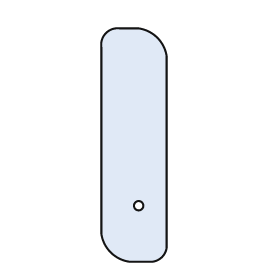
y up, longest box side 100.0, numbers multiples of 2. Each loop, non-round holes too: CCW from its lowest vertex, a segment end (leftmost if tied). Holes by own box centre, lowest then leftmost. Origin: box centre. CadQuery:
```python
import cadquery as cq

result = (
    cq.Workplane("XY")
    .moveTo(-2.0, -50.0)
    .lineTo(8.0, -50.0)
    .threePointArc((12.0, -48.0), (14.0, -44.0))
    .lineTo(14.0, 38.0)
    .threePointArc((10.0, 46.0), (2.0, 50.0))
    .lineTo(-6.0, 50.0)
    .threePointArc((-12.0, 48.0), (-14.0, 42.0))
    .lineTo(-14.0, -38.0)
    .threePointArc((-10.0, -46.0), (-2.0, -50.0))
    .close()
    .moveTo(2.0, -26.0)
    .circle(2.0)
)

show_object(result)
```